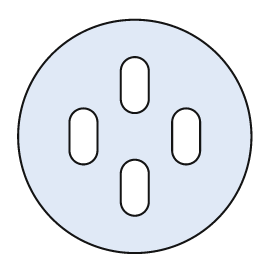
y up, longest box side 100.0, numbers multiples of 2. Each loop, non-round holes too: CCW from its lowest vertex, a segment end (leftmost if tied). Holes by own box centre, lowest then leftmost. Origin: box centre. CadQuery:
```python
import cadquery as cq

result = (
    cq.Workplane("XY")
    .moveTo(0.0, 0.0)
    .circle(50.0)
    .moveTo(-6.0, -28.0)
    .threePointArc((0.0, -34.0), (6.0, -28.0))
    .lineTo(6.0, -16.0)
    .threePointArc((0.0, -10.0), (-6.0, -16.0))
    .close()
    .moveTo(-28.0, -6.0)
    .threePointArc((-22.0, -12.0), (-16.0, -6.0))
    .lineTo(-16.0, 6.0)
    .threePointArc((-22.0, 12.0), (-28.0, 6.0))
    .close()
    .moveTo(16.0, -6.0)
    .threePointArc((22.0, -12.0), (28.0, -6.0))
    .lineTo(28.0, 6.0)
    .threePointArc((22.0, 12.0), (16.0, 6.0))
    .close()
    .moveTo(-6.0, 16.0)
    .threePointArc((0.0, 10.0), (6.0, 16.0))
    .lineTo(6.0, 28.0)
    .threePointArc((0.0, 34.0), (-6.0, 28.0))
    .close()
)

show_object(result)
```